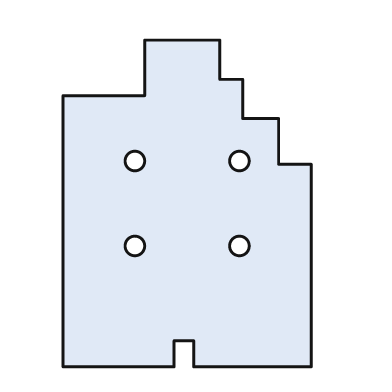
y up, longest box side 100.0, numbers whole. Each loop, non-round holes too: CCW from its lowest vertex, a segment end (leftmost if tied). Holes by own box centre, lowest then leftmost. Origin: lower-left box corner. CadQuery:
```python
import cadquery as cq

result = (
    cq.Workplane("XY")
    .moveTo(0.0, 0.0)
    .lineTo(34.0, 0.0)
    .lineTo(34.0, 8.0)
    .lineTo(40.0, 8.0)
    .lineTo(40.0, 0.0)
    .lineTo(76.0, 0.0)
    .lineTo(76.0, 62.0)
    .lineTo(66.0, 62.0)
    .lineTo(66.0, 76.0)
    .lineTo(55.0, 76.0)
    .lineTo(55.0, 88.0)
    .lineTo(48.0, 88.0)
    .lineTo(48.0, 100.0)
    .lineTo(25.0, 100.0)
    .lineTo(25.0, 83.0)
    .lineTo(0.0, 83.0)
    .close()
    .moveTo(22.0, 37.0)
    .circle(3.0)
    .moveTo(54.0, 37.0)
    .circle(3.0)
    .moveTo(22.0, 63.0)
    .circle(3.0)
    .moveTo(54.0, 63.0)
    .circle(3.0)
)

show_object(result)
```